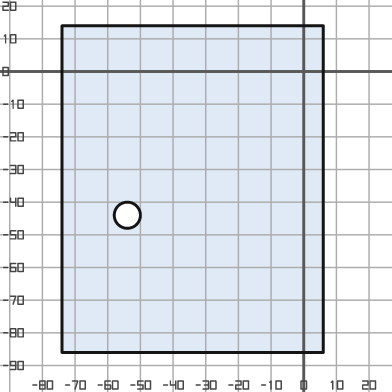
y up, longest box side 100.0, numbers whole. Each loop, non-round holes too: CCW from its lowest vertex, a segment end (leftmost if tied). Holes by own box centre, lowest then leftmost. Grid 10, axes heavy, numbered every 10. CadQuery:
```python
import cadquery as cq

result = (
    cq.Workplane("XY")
    .moveTo(-74.0, -86.0)
    .lineTo(6.0, -86.0)
    .lineTo(6.0, 14.0)
    .lineTo(-74.0, 14.0)
    .close()
    .moveTo(-54.0, -44.0)
    .circle(4.0)
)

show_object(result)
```